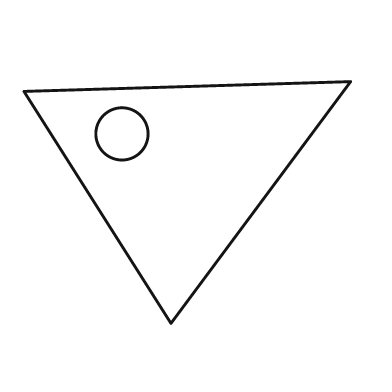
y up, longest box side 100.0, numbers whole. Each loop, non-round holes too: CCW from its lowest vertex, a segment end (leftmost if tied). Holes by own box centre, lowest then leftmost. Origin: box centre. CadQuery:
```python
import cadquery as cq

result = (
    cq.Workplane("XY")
    .moveTo(-5.0, -37.0)
    .lineTo(50.0, 37.0)
    .lineTo(-50.0, 34.0)
    .close()
    .moveTo(-20.0, 21.0)
    .circle(8.0)
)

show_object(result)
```